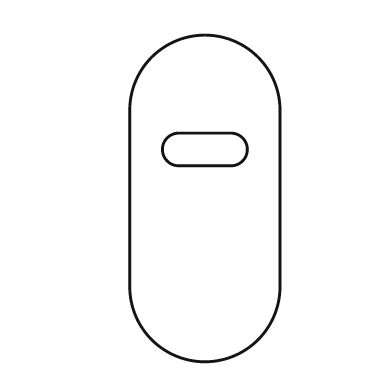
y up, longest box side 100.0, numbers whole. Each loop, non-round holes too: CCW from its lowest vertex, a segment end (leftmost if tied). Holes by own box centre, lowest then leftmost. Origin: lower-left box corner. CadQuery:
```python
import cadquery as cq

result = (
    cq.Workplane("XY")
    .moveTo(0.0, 23.0)
    .threePointArc((23.0, 0.0), (46.0, 23.0))
    .lineTo(46.0, 77.0)
    .threePointArc((23.0, 100.0), (0.0, 77.0))
    .close()
    .moveTo(15.0, 60.0)
    .lineTo(31.0, 60.0)
    .threePointArc((36.0, 65.0), (31.0, 70.0))
    .lineTo(15.0, 70.0)
    .threePointArc((10.0, 65.0), (15.0, 60.0))
    .close()
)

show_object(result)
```